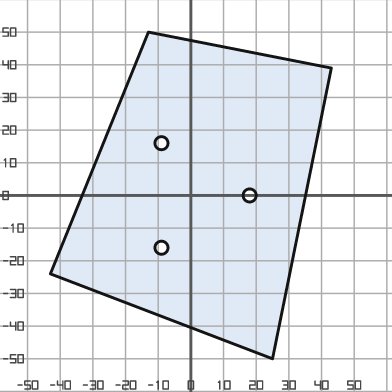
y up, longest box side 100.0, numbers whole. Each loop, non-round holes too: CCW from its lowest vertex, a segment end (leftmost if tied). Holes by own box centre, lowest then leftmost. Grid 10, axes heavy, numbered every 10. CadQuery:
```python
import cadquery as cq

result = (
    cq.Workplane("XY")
    .moveTo(25.0, -50.0)
    .lineTo(43.0, 39.0)
    .lineTo(-13.0, 50.0)
    .lineTo(-43.0, -24.0)
    .close()
    .moveTo(-9.0, -16.0)
    .circle(2.0)
    .moveTo(18.0, 0.0)
    .circle(2.0)
    .moveTo(-9.0, 16.0)
    .circle(2.0)
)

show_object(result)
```